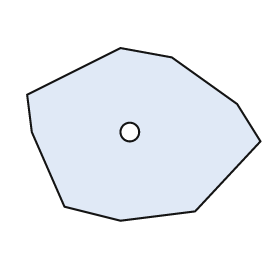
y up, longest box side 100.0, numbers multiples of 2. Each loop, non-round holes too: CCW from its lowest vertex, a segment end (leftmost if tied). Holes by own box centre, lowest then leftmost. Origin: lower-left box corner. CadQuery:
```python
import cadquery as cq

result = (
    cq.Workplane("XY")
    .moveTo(40.0, 0.0)
    .lineTo(72.0, 4.0)
    .lineTo(100.0, 34.0)
    .lineTo(90.0, 50.0)
    .lineTo(62.0, 70.0)
    .lineTo(40.0, 74.0)
    .lineTo(0.0, 54.0)
    .lineTo(2.0, 38.0)
    .lineTo(16.0, 6.0)
    .close()
    .moveTo(44.0, 38.0)
    .circle(4.0)
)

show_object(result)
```